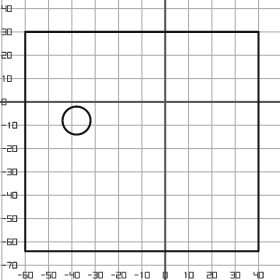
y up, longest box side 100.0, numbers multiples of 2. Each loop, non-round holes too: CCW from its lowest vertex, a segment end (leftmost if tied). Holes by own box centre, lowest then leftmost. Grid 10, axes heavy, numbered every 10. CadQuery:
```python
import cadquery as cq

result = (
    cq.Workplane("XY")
    .moveTo(-60.0, -64.0)
    .lineTo(40.0, -64.0)
    .lineTo(40.0, 30.0)
    .lineTo(-60.0, 30.0)
    .close()
    .moveTo(-38.0, -8.0)
    .circle(6.0)
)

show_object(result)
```